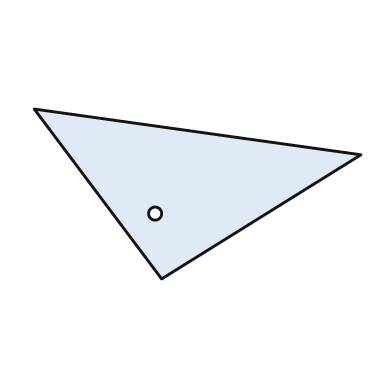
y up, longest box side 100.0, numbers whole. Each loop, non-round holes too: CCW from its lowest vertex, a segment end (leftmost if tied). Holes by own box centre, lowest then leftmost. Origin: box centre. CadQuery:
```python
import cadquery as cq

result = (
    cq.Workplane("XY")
    .moveTo(-11.0, -26.0)
    .lineTo(50.0, 12.0)
    .lineTo(-50.0, 26.0)
    .close()
    .moveTo(-13.0, -6.0)
    .circle(2.0)
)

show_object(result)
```